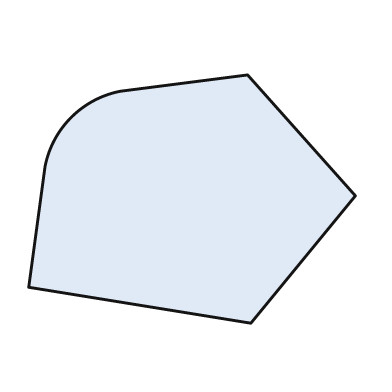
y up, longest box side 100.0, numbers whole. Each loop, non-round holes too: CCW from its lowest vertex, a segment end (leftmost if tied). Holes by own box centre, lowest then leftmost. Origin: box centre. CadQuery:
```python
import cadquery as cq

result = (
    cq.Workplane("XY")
    .moveTo(18.0, -38.0)
    .lineTo(50.0, 1.0)
    .lineTo(17.0, 38.0)
    .lineTo(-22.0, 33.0)
    .threePointArc((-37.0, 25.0), (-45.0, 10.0))
    .lineTo(-50.0, -27.0)
    .close()
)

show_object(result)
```